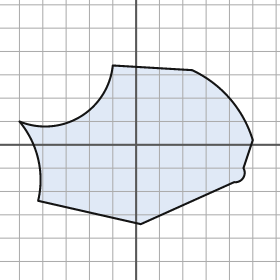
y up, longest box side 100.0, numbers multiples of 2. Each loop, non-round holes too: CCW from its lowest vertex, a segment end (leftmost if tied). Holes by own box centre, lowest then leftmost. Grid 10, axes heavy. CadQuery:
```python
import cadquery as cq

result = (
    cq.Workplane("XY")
    .moveTo(2.0, -34.0)
    .lineTo(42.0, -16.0)
    .threePointArc((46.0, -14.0), (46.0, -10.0))
    .lineTo(50.0, 2.0)
    .threePointArc((40.0, 20.0), (24.0, 32.0))
    .lineTo(-10.0, 34.0)
    .threePointArc((-24.0, 12.0), (-50.0, 10.0))
    .threePointArc((-42.0, -6.0), (-42.0, -24.0))
    .close()
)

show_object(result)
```